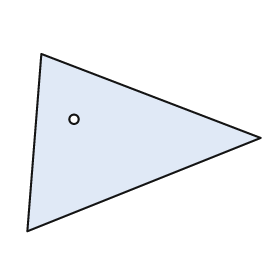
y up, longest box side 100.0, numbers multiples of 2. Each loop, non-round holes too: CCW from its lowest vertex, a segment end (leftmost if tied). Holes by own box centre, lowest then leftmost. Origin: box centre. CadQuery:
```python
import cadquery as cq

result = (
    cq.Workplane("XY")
    .moveTo(-50.0, -38.0)
    .lineTo(50.0, 2.0)
    .lineTo(-44.0, 38.0)
    .close()
    .moveTo(-30.0, 10.0)
    .circle(2.0)
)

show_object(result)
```